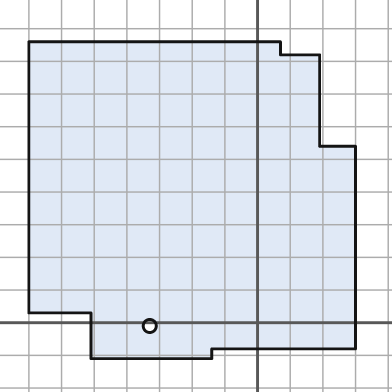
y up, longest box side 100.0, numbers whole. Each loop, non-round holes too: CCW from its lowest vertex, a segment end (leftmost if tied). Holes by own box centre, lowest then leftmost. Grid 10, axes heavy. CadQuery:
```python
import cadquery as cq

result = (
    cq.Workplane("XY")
    .moveTo(-51.0, -11.0)
    .lineTo(-14.0, -11.0)
    .lineTo(-14.0, -8.0)
    .lineTo(30.0, -8.0)
    .lineTo(30.0, 54.0)
    .lineTo(19.0, 54.0)
    .lineTo(19.0, 82.0)
    .lineTo(7.0, 82.0)
    .lineTo(7.0, 86.0)
    .lineTo(-70.0, 86.0)
    .lineTo(-70.0, 3.0)
    .lineTo(-51.0, 3.0)
    .close()
    .moveTo(-33.0, -1.0)
    .circle(2.0)
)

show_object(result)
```